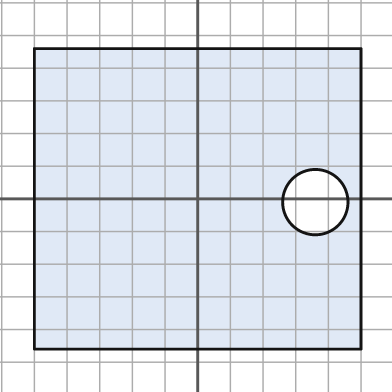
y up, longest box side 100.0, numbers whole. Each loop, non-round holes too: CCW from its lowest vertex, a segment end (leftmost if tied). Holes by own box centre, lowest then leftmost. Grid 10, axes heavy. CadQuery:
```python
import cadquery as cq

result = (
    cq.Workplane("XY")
    .moveTo(-50.0, -46.0)
    .lineTo(50.0, -46.0)
    .lineTo(50.0, 46.0)
    .lineTo(-50.0, 46.0)
    .close()
    .moveTo(36.0, -1.0)
    .circle(10.0)
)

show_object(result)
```